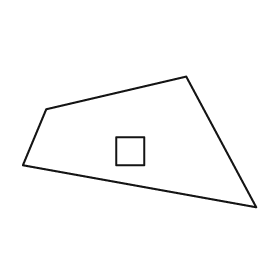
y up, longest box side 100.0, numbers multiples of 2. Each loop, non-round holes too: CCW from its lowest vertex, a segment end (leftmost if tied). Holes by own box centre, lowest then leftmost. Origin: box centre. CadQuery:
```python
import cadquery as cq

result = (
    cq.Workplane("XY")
    .moveTo(50.0, -28.0)
    .lineTo(20.0, 28.0)
    .lineTo(-40.0, 14.0)
    .lineTo(-50.0, -10.0)
    .close()
    .moveTo(-10.0, -10.0)
    .lineTo(2.0, -10.0)
    .lineTo(2.0, 2.0)
    .lineTo(-10.0, 2.0)
    .close()
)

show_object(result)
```